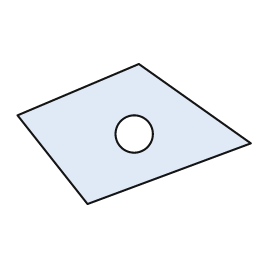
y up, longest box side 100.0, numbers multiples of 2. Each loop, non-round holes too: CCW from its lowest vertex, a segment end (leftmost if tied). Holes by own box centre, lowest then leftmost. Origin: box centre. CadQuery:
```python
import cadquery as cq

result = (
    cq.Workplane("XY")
    .moveTo(-20.0, -30.0)
    .lineTo(50.0, -4.0)
    .lineTo(2.0, 30.0)
    .lineTo(-50.0, 8.0)
    .close()
    .moveTo(0.0, 0.0)
    .circle(8.0)
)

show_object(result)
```